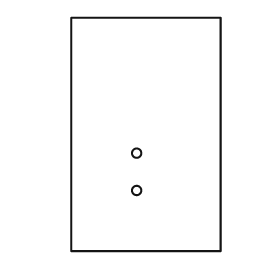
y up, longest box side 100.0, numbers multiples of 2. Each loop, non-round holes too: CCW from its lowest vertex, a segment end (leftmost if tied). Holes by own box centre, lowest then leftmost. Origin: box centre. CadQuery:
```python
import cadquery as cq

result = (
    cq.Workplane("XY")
    .moveTo(-32.0, -50.0)
    .lineTo(32.0, -50.0)
    .lineTo(32.0, 50.0)
    .lineTo(-32.0, 50.0)
    .close()
    .moveTo(-4.0, -24.0)
    .circle(2.0)
    .moveTo(-4.0, -8.0)
    .circle(2.0)
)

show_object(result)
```